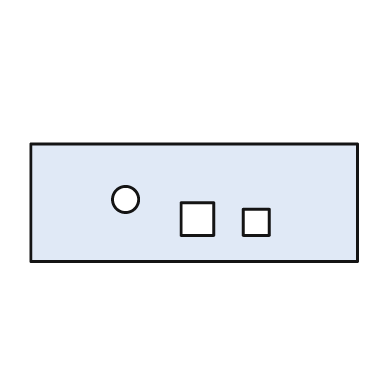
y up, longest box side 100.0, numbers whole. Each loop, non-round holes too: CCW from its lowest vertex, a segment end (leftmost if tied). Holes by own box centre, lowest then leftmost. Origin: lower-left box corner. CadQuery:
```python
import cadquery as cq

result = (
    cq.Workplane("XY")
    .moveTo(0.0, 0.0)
    .lineTo(100.0, 0.0)
    .lineTo(100.0, 36.0)
    .lineTo(0.0, 36.0)
    .close()
    .moveTo(65.0, 8.0)
    .lineTo(73.0, 8.0)
    .lineTo(73.0, 16.0)
    .lineTo(65.0, 16.0)
    .close()
    .moveTo(46.0, 8.0)
    .lineTo(56.0, 8.0)
    .lineTo(56.0, 18.0)
    .lineTo(46.0, 18.0)
    .close()
    .moveTo(29.0, 19.0)
    .circle(4.0)
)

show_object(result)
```